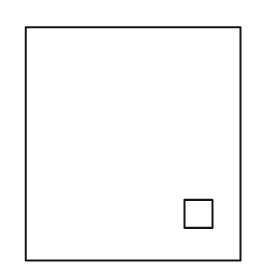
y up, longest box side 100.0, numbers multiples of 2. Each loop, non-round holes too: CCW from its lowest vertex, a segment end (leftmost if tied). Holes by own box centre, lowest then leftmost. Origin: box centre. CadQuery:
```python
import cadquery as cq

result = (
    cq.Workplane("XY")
    .moveTo(-46.0, -50.0)
    .lineTo(46.0, -50.0)
    .lineTo(46.0, 50.0)
    .lineTo(-46.0, 50.0)
    .close()
    .moveTo(22.0, -36.0)
    .lineTo(34.0, -36.0)
    .lineTo(34.0, -24.0)
    .lineTo(22.0, -24.0)
    .close()
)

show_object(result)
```